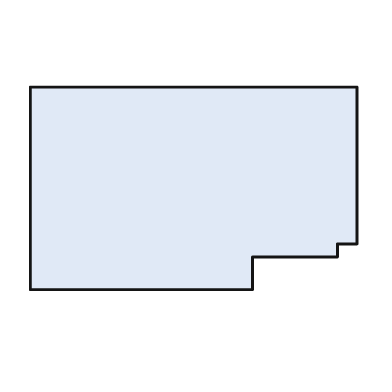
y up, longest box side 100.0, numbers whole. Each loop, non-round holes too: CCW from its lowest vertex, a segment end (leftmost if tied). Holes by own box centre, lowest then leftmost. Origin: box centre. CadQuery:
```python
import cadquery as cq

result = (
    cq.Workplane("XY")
    .moveTo(-50.0, -31.0)
    .lineTo(18.0, -31.0)
    .lineTo(18.0, -21.0)
    .lineTo(44.0, -21.0)
    .lineTo(44.0, -17.0)
    .lineTo(50.0, -17.0)
    .lineTo(50.0, 31.0)
    .lineTo(-50.0, 31.0)
    .close()
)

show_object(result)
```